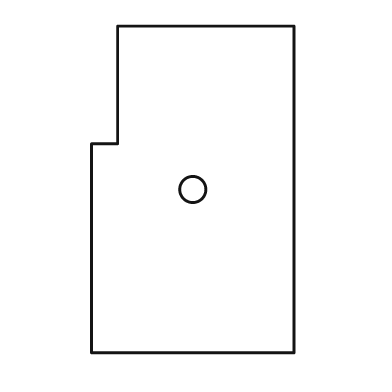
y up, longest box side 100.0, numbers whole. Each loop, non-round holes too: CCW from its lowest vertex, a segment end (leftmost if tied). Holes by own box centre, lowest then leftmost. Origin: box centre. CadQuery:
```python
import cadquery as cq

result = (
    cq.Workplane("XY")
    .moveTo(-31.0, -50.0)
    .lineTo(31.0, -50.0)
    .lineTo(31.0, 50.0)
    .lineTo(-23.0, 50.0)
    .lineTo(-23.0, 14.0)
    .lineTo(-31.0, 14.0)
    .close()
    .moveTo(0.0, 0.0)
    .circle(4.0)
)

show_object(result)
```